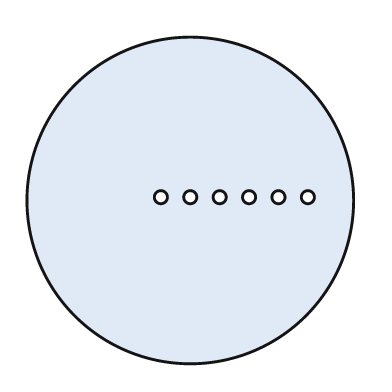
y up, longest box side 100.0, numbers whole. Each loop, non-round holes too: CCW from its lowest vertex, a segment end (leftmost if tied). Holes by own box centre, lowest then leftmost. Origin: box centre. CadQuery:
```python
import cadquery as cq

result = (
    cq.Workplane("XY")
    .moveTo(0.0, 0.0)
    .circle(50.0)
    .moveTo(-9.0, 1.0)
    .circle(2.0)
    .moveTo(0.0, 1.0)
    .circle(2.0)
    .moveTo(9.0, 1.0)
    .circle(2.0)
    .moveTo(18.0, 1.0)
    .circle(2.0)
    .moveTo(27.0, 1.0)
    .circle(2.0)
    .moveTo(36.0, 1.0)
    .circle(2.0)
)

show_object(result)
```